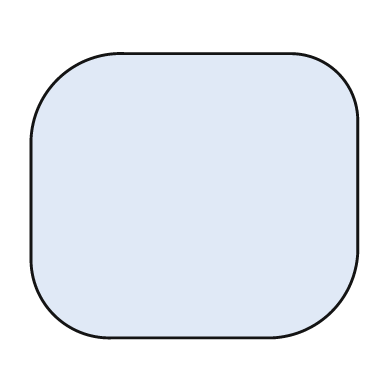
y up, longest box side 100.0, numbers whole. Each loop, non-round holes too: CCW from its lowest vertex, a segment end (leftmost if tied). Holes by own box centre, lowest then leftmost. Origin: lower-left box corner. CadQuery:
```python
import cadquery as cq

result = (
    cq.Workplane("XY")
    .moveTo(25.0, 0.0)
    .lineTo(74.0, 0.0)
    .threePointArc((92.0, 8.0), (100.0, 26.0))
    .lineTo(100.0, 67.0)
    .threePointArc((94.0, 81.0), (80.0, 87.0))
    .lineTo(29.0, 87.0)
    .threePointArc((8.0, 79.0), (0.0, 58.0))
    .lineTo(0.0, 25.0)
    .threePointArc((7.0, 7.0), (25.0, 0.0))
    .close()
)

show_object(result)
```